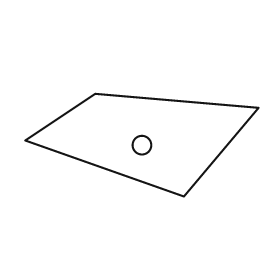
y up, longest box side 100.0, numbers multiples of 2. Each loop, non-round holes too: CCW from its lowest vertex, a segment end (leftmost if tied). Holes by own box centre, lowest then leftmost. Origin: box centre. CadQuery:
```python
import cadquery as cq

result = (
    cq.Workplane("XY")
    .moveTo(18.0, -22.0)
    .lineTo(50.0, 16.0)
    .lineTo(-20.0, 22.0)
    .lineTo(-50.0, 2.0)
    .close()
    .moveTo(0.0, 0.0)
    .circle(4.0)
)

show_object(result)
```